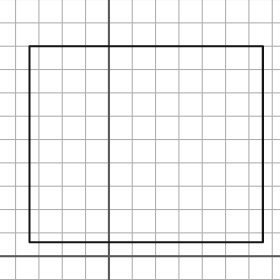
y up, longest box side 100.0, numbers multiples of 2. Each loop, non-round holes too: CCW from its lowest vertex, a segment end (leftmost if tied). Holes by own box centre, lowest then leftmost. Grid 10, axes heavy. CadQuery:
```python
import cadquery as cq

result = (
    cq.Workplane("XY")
    .moveTo(-34.0, 6.0)
    .lineTo(66.0, 6.0)
    .lineTo(66.0, 90.0)
    .lineTo(-34.0, 90.0)
    .close()
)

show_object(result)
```